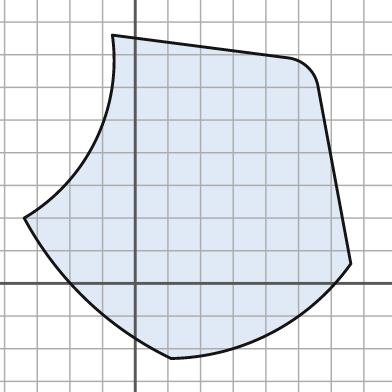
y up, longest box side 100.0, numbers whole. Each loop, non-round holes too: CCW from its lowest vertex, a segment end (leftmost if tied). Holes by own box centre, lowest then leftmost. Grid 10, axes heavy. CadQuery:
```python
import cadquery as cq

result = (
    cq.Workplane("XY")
    .moveTo(11.0, -23.0)
    .threePointArc((42.0, -15.0), (66.0, 6.0))
    .lineTo(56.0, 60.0)
    .threePointArc((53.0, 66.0), (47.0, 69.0))
    .lineTo(-7.0, 76.0)
    .threePointArc((-12.0, 44.0), (-34.0, 20.0))
    .threePointArc((-15.0, -5.0), (11.0, -23.0))
    .close()
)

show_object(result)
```